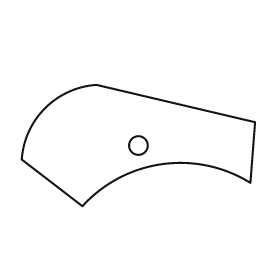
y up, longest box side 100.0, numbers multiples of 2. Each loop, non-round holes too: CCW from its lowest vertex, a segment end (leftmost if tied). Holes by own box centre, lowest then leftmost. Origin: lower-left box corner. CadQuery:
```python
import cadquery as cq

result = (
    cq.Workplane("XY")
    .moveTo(26.0, 0.0)
    .threePointArc((60.0, 18.0), (98.0, 10.0))
    .lineTo(100.0, 36.0)
    .lineTo(32.0, 52.0)
    .threePointArc((10.0, 42.0), (0.0, 20.0))
    .close()
    .moveTo(50.0, 26.0)
    .circle(4.0)
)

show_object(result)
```